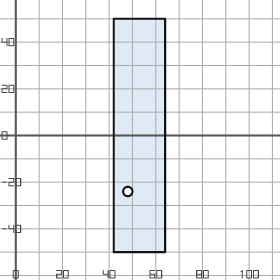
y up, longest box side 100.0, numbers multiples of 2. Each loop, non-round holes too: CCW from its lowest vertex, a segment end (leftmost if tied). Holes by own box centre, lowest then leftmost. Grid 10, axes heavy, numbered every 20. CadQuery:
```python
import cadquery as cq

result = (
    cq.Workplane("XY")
    .moveTo(42.0, -50.0)
    .lineTo(64.0, -50.0)
    .lineTo(64.0, 50.0)
    .lineTo(42.0, 50.0)
    .close()
    .moveTo(48.0, -24.0)
    .circle(2.0)
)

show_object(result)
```